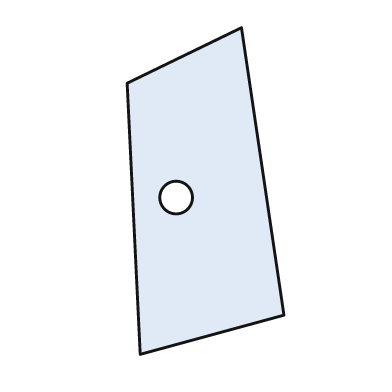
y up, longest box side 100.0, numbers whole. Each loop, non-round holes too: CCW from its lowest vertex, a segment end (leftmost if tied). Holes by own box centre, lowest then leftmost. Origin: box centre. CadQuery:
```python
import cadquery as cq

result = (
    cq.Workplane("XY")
    .moveTo(-20.0, -50.0)
    .lineTo(24.0, -38.0)
    .lineTo(11.0, 50.0)
    .lineTo(-24.0, 33.0)
    .close()
    .moveTo(-9.0, -2.0)
    .circle(5.0)
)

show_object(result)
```